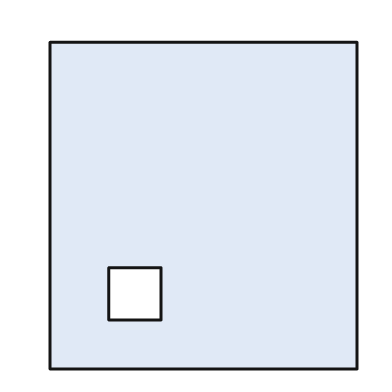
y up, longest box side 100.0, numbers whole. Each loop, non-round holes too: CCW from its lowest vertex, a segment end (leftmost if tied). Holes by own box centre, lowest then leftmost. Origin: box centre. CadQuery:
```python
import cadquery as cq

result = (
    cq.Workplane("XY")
    .moveTo(-47.0, -50.0)
    .lineTo(47.0, -50.0)
    .lineTo(47.0, 50.0)
    .lineTo(-47.0, 50.0)
    .close()
    .moveTo(-29.0, -35.0)
    .lineTo(-13.0, -35.0)
    .lineTo(-13.0, -19.0)
    .lineTo(-29.0, -19.0)
    .close()
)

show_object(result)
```